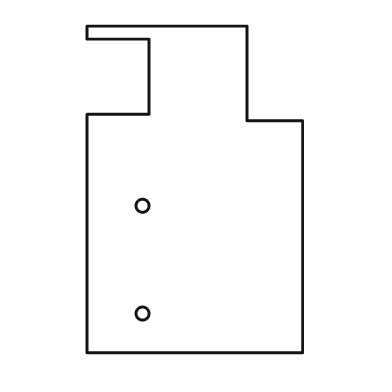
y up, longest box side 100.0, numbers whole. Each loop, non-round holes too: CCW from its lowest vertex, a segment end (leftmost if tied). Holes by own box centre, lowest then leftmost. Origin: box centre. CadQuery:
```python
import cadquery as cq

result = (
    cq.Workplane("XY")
    .moveTo(-33.0, -50.0)
    .lineTo(33.0, -50.0)
    .lineTo(33.0, 21.0)
    .lineTo(16.0, 21.0)
    .lineTo(16.0, 50.0)
    .lineTo(-33.0, 50.0)
    .lineTo(-33.0, 46.0)
    .lineTo(-14.0, 46.0)
    .lineTo(-14.0, 23.0)
    .lineTo(-33.0, 23.0)
    .close()
    .moveTo(-16.0, -38.0)
    .circle(2.0)
    .moveTo(-16.0, -5.0)
    .circle(2.0)
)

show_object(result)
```